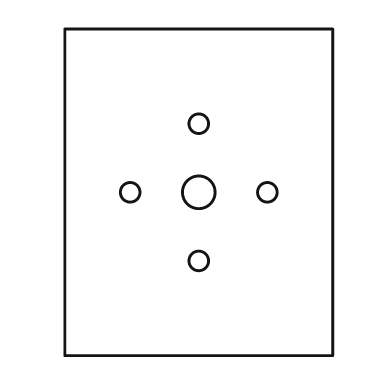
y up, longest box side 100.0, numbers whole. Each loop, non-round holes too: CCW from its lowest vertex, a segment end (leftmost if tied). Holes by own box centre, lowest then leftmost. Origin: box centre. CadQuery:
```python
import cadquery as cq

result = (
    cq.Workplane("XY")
    .moveTo(-41.0, -50.0)
    .lineTo(41.0, -50.0)
    .lineTo(41.0, 50.0)
    .lineTo(-41.0, 50.0)
    .close()
    .moveTo(0.0, -21.0)
    .circle(3.0)
    .moveTo(-21.0, 0.0)
    .circle(3.0)
    .moveTo(0.0, 0.0)
    .circle(5.0)
    .moveTo(21.0, 0.0)
    .circle(3.0)
    .moveTo(0.0, 21.0)
    .circle(3.0)
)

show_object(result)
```